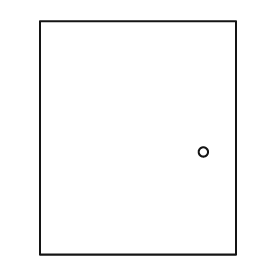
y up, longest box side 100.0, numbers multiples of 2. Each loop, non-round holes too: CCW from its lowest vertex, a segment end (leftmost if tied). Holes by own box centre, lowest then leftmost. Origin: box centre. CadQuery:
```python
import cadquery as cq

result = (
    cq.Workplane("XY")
    .moveTo(-42.0, -50.0)
    .lineTo(42.0, -50.0)
    .lineTo(42.0, 50.0)
    .lineTo(-42.0, 50.0)
    .close()
    .moveTo(28.0, -6.0)
    .circle(2.0)
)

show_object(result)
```